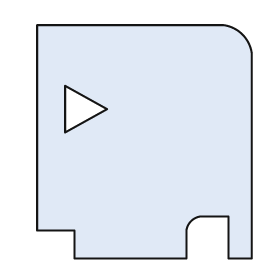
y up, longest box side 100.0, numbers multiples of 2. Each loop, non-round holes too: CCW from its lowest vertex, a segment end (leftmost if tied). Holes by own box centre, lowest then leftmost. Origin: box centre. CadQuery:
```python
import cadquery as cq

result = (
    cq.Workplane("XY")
    .moveTo(-30.0, -50.0)
    .lineTo(18.0, -50.0)
    .lineTo(18.0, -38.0)
    .threePointArc((20.0, -34.0), (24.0, -32.0))
    .lineTo(36.0, -32.0)
    .lineTo(36.0, -50.0)
    .lineTo(46.0, -50.0)
    .lineTo(46.0, 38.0)
    .threePointArc((42.0, 46.0), (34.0, 50.0))
    .lineTo(-46.0, 50.0)
    .lineTo(-46.0, -38.0)
    .lineTo(-30.0, -38.0)
    .close()
    .moveTo(-34.0, 4.0)
    .lineTo(-16.0, 14.0)
    .lineTo(-34.0, 24.0)
    .close()
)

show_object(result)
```